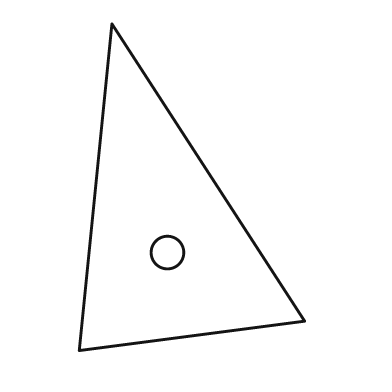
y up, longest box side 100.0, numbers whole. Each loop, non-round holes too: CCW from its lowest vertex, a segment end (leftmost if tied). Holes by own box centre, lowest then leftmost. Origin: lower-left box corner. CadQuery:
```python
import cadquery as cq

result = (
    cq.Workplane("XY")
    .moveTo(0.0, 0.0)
    .lineTo(69.0, 9.0)
    .lineTo(10.0, 100.0)
    .close()
    .moveTo(27.0, 30.0)
    .circle(5.0)
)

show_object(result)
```